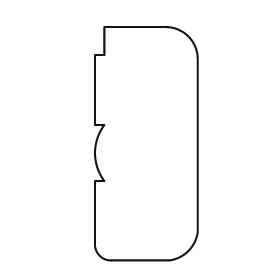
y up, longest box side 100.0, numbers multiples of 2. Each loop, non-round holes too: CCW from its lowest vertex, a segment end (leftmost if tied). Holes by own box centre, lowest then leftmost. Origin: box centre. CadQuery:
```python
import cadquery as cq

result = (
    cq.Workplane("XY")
    .moveTo(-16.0, -50.0)
    .lineTo(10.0, -50.0)
    .threePointArc((18.0, -46.0), (22.0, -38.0))
    .lineTo(22.0, 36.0)
    .threePointArc((18.0, 46.0), (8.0, 50.0))
    .lineTo(-18.0, 50.0)
    .lineTo(-18.0, 38.0)
    .lineTo(-22.0, 38.0)
    .lineTo(-22.0, 8.0)
    .lineTo(-18.0, 8.0)
    .threePointArc((-22.0, -4.0), (-18.0, -16.0))
    .lineTo(-22.0, -16.0)
    .lineTo(-22.0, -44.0)
    .threePointArc((-20.0, -48.0), (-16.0, -50.0))
    .close()
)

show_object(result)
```